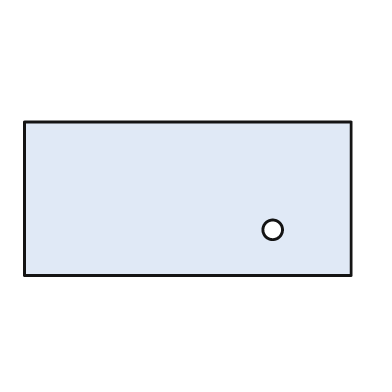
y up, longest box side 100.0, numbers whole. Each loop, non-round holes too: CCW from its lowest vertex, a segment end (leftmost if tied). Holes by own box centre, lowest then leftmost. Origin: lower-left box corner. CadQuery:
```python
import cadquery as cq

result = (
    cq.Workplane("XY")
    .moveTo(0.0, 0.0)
    .lineTo(100.0, 0.0)
    .lineTo(100.0, 47.0)
    .lineTo(0.0, 47.0)
    .close()
    .moveTo(76.0, 14.0)
    .circle(3.0)
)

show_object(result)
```